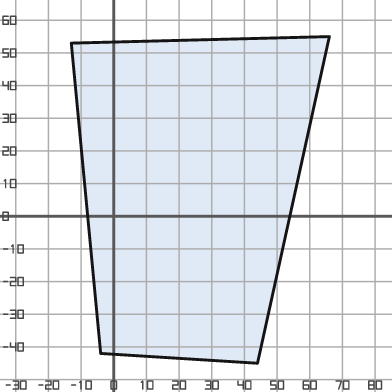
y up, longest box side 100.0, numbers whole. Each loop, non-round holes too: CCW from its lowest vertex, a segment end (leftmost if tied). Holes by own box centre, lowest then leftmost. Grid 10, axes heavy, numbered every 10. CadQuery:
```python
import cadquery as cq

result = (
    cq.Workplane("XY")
    .moveTo(44.0, -45.0)
    .lineTo(66.0, 55.0)
    .lineTo(-13.0, 53.0)
    .lineTo(-4.0, -42.0)
    .close()
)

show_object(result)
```